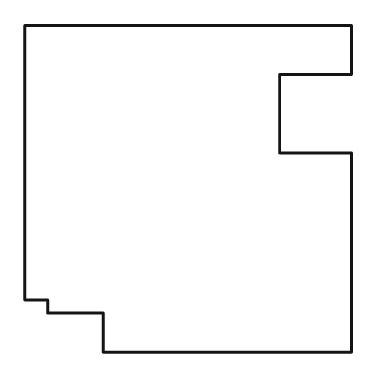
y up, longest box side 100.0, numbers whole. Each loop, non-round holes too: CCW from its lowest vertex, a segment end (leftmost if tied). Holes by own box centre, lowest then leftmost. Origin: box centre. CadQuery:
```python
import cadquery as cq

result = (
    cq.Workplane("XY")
    .moveTo(-26.0, -50.0)
    .lineTo(50.0, -50.0)
    .lineTo(50.0, 11.0)
    .lineTo(28.0, 11.0)
    .lineTo(28.0, 35.0)
    .lineTo(50.0, 35.0)
    .lineTo(50.0, 50.0)
    .lineTo(-50.0, 50.0)
    .lineTo(-50.0, -34.0)
    .lineTo(-43.0, -34.0)
    .lineTo(-43.0, -38.0)
    .lineTo(-26.0, -38.0)
    .close()
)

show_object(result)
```